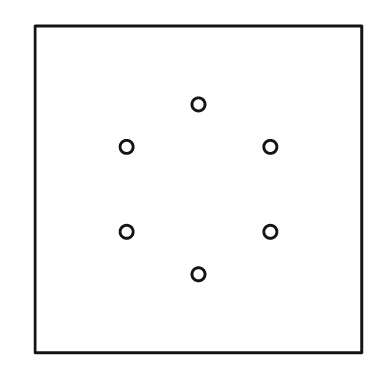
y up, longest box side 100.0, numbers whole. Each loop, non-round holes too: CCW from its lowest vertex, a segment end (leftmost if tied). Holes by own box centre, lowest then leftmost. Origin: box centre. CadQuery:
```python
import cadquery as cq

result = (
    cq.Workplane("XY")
    .moveTo(-50.0, -50.0)
    .lineTo(50.0, -50.0)
    .lineTo(50.0, 50.0)
    .lineTo(-50.0, 50.0)
    .close()
    .moveTo(0.0, -26.0)
    .circle(2.0)
    .moveTo(-22.0, -13.0)
    .circle(2.0)
    .moveTo(22.0, -13.0)
    .circle(2.0)
    .moveTo(-22.0, 13.0)
    .circle(2.0)
    .moveTo(22.0, 13.0)
    .circle(2.0)
    .moveTo(0.0, 26.0)
    .circle(2.0)
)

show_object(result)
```